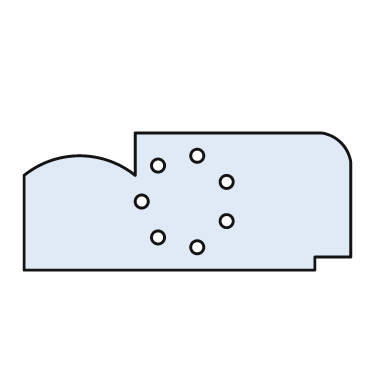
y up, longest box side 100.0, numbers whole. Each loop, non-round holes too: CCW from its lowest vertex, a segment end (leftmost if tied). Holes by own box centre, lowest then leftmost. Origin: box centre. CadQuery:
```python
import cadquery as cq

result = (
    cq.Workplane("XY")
    .moveTo(-50.0, -21.0)
    .lineTo(39.0, -21.0)
    .lineTo(39.0, -17.0)
    .lineTo(50.0, -17.0)
    .lineTo(50.0, 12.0)
    .threePointArc((47.0, 18.0), (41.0, 21.0))
    .lineTo(-16.0, 21.0)
    .lineTo(-16.0, 8.0)
    .threePointArc((-33.0, 14.0), (-50.0, 8.0))
    .close()
    .moveTo(3.0, -14.0)
    .circle(2.0)
    .moveTo(-9.0, -11.0)
    .circle(2.0)
    .moveTo(12.0, -6.0)
    .circle(2.0)
    .moveTo(-14.0, 0.0)
    .circle(2.0)
    .moveTo(12.0, 6.0)
    .circle(2.0)
    .moveTo(-9.0, 11.0)
    .circle(2.0)
    .moveTo(3.0, 14.0)
    .circle(2.0)
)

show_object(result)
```